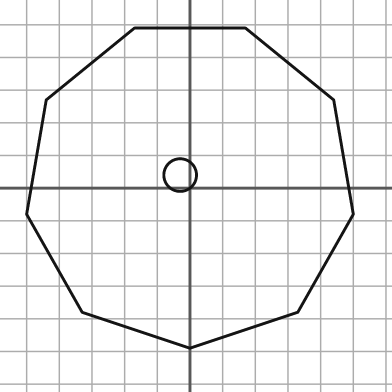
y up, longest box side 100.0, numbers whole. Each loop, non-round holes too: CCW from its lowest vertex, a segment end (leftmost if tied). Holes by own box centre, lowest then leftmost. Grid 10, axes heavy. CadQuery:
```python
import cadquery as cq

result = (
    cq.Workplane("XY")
    .moveTo(0.0, -49.0)
    .lineTo(33.0, -38.0)
    .lineTo(50.0, -8.0)
    .lineTo(44.0, 27.0)
    .lineTo(17.0, 49.0)
    .lineTo(-17.0, 49.0)
    .lineTo(-44.0, 27.0)
    .lineTo(-50.0, -8.0)
    .lineTo(-33.0, -38.0)
    .close()
    .moveTo(-3.0, 4.0)
    .circle(5.0)
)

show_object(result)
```